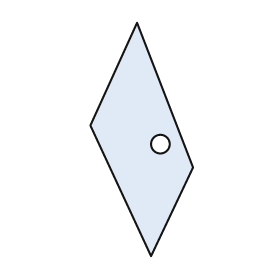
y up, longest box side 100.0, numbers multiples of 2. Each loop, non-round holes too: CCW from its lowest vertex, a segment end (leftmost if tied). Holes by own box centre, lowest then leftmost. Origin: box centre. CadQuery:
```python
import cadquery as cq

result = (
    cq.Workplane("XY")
    .moveTo(4.0, -50.0)
    .lineTo(22.0, -12.0)
    .lineTo(-2.0, 50.0)
    .lineTo(-22.0, 6.0)
    .close()
    .moveTo(8.0, -2.0)
    .circle(4.0)
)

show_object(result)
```